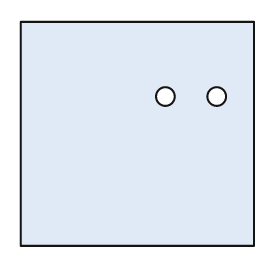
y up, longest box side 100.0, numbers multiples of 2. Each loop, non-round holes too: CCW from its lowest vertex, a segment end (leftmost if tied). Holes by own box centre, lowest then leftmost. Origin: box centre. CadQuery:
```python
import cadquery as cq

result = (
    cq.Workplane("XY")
    .moveTo(-50.0, -48.0)
    .lineTo(50.0, -48.0)
    .lineTo(50.0, 48.0)
    .lineTo(-50.0, 48.0)
    .close()
    .moveTo(12.0, 16.0)
    .circle(4.0)
    .moveTo(34.0, 16.0)
    .circle(4.0)
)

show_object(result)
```